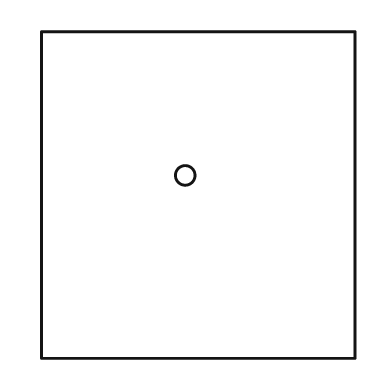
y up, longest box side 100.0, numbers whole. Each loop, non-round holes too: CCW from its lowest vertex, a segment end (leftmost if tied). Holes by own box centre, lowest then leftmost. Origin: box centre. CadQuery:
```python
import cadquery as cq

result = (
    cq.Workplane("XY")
    .moveTo(-48.0, -50.0)
    .lineTo(48.0, -50.0)
    .lineTo(48.0, 50.0)
    .lineTo(-48.0, 50.0)
    .close()
    .moveTo(-4.0, 6.0)
    .circle(3.0)
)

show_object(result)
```